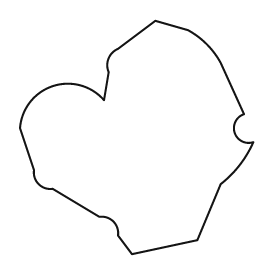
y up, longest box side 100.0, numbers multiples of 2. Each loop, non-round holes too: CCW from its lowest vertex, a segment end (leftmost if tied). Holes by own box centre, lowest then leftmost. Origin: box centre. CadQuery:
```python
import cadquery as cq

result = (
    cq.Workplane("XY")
    .moveTo(-2.0, -50.0)
    .lineTo(26.0, -44.0)
    .lineTo(36.0, -20.0)
    .threePointArc((44.0, -12.0), (50.0, -2.0))
    .threePointArc((42.0, 2.0), (46.0, 10.0))
    .lineTo(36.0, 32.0)
    .threePointArc((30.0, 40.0), (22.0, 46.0))
    .lineTo(8.0, 50.0)
    .lineTo(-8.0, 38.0)
    .threePointArc((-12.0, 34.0), (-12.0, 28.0))
    .lineTo(-14.0, 16.0)
    .threePointArc((-36.0, 22.0), (-50.0, 4.0))
    .lineTo(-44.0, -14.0)
    .threePointArc((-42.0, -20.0), (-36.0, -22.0))
    .lineTo(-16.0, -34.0)
    .threePointArc((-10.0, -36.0), (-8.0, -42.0))
    .close()
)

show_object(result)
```